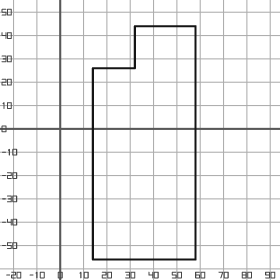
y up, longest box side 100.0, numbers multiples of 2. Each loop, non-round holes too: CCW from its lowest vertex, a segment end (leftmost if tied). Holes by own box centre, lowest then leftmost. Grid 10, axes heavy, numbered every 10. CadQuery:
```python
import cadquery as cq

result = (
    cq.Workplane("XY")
    .moveTo(14.0, -56.0)
    .lineTo(58.0, -56.0)
    .lineTo(58.0, 44.0)
    .lineTo(32.0, 44.0)
    .lineTo(32.0, 26.0)
    .lineTo(14.0, 26.0)
    .close()
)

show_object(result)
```